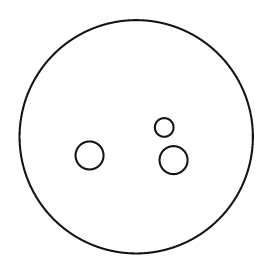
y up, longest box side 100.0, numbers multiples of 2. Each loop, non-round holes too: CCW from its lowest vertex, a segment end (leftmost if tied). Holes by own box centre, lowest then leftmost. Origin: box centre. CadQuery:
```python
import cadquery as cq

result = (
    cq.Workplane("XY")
    .moveTo(0.0, 0.0)
    .circle(50.0)
    .moveTo(16.0, -10.0)
    .circle(6.0)
    .moveTo(-20.0, -8.0)
    .circle(6.0)
    .moveTo(12.0, 4.0)
    .circle(4.0)
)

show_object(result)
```